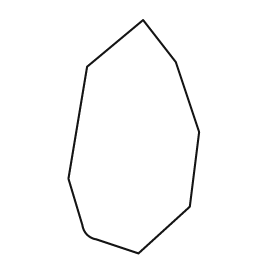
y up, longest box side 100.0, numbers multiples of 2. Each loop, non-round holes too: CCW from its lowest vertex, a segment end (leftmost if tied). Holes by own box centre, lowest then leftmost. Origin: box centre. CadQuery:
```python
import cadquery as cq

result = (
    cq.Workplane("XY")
    .moveTo(2.0, -50.0)
    .lineTo(24.0, -30.0)
    .lineTo(28.0, 2.0)
    .lineTo(18.0, 32.0)
    .lineTo(4.0, 50.0)
    .lineTo(-20.0, 30.0)
    .lineTo(-28.0, -18.0)
    .lineTo(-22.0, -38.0)
    .threePointArc((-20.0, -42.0), (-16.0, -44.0))
    .close()
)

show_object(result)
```